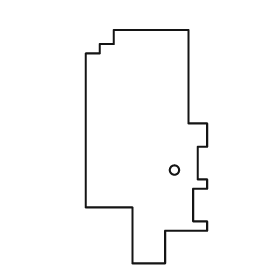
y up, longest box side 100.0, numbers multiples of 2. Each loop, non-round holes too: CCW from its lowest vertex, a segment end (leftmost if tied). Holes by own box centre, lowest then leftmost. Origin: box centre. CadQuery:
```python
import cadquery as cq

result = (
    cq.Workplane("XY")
    .moveTo(-6.0, -50.0)
    .lineTo(8.0, -50.0)
    .lineTo(8.0, -36.0)
    .lineTo(26.0, -36.0)
    .lineTo(26.0, -32.0)
    .lineTo(20.0, -32.0)
    .lineTo(20.0, -18.0)
    .lineTo(26.0, -18.0)
    .lineTo(26.0, -14.0)
    .lineTo(22.0, -14.0)
    .lineTo(22.0, 0.0)
    .lineTo(26.0, 0.0)
    .lineTo(26.0, 10.0)
    .lineTo(18.0, 10.0)
    .lineTo(18.0, 50.0)
    .lineTo(-14.0, 50.0)
    .lineTo(-14.0, 44.0)
    .lineTo(-20.0, 44.0)
    .lineTo(-20.0, 40.0)
    .lineTo(-26.0, 40.0)
    .lineTo(-26.0, -26.0)
    .lineTo(-6.0, -26.0)
    .close()
    .moveTo(12.0, -10.0)
    .circle(2.0)
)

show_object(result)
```